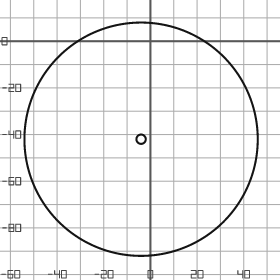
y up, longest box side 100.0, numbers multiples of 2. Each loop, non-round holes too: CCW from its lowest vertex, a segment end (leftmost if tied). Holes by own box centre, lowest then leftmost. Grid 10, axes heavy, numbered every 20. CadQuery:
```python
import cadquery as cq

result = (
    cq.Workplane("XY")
    .moveTo(-4.0, -42.0)
    .circle(50.0)
    .moveTo(-4.0, -42.0)
    .circle(2.0)
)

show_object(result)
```